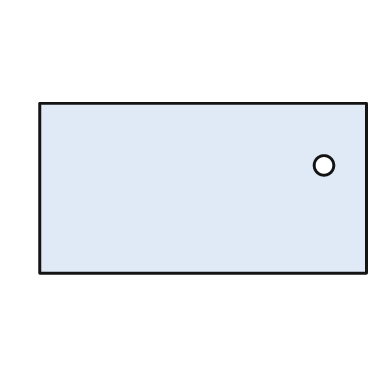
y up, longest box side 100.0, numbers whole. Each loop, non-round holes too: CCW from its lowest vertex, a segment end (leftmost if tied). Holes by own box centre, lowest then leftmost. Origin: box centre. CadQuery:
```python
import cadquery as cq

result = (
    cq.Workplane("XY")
    .moveTo(-50.0, -26.0)
    .lineTo(50.0, -26.0)
    .lineTo(50.0, 26.0)
    .lineTo(-50.0, 26.0)
    .close()
    .moveTo(37.0, 7.0)
    .circle(3.0)
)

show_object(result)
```